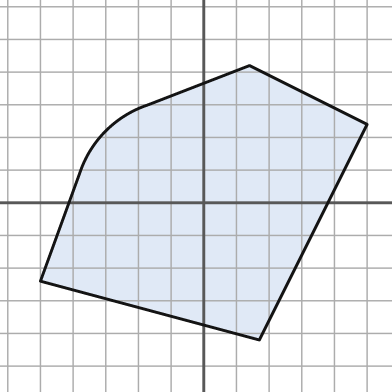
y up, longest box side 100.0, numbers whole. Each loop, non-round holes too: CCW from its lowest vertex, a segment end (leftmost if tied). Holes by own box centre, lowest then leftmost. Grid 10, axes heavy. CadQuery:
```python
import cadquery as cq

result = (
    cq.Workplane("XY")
    .moveTo(17.0, -42.0)
    .lineTo(50.0, 24.0)
    .lineTo(14.0, 42.0)
    .lineTo(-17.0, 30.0)
    .threePointArc((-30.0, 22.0), (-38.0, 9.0))
    .lineTo(-50.0, -24.0)
    .close()
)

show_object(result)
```